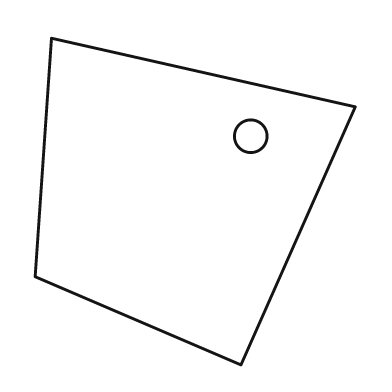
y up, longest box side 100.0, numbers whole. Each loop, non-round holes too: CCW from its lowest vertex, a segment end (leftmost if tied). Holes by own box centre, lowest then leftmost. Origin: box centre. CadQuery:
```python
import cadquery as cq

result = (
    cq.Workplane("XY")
    .moveTo(14.0, -50.0)
    .lineTo(49.0, 29.0)
    .lineTo(-44.0, 50.0)
    .lineTo(-49.0, -23.0)
    .close()
    .moveTo(17.0, 20.0)
    .circle(5.0)
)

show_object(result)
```